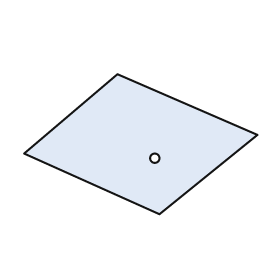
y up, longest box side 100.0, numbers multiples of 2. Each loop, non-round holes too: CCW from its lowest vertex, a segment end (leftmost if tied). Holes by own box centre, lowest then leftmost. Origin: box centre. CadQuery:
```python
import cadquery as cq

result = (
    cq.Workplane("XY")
    .moveTo(8.0, -30.0)
    .lineTo(50.0, 4.0)
    .lineTo(-10.0, 30.0)
    .lineTo(-50.0, -4.0)
    .close()
    .moveTo(6.0, -6.0)
    .circle(2.0)
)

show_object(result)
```